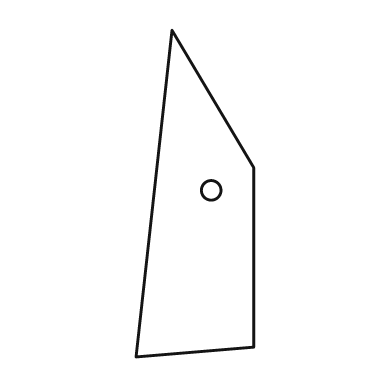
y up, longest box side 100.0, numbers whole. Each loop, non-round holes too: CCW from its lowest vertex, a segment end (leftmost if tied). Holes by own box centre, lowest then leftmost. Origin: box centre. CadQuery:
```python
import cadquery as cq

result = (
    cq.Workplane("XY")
    .moveTo(-18.0, -50.0)
    .lineTo(18.0, -47.0)
    .lineTo(18.0, 8.0)
    .lineTo(-7.0, 50.0)
    .close()
    .moveTo(5.0, 1.0)
    .circle(3.0)
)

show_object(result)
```